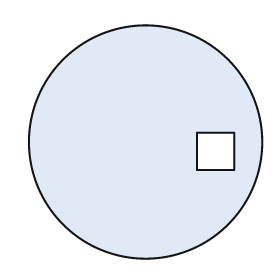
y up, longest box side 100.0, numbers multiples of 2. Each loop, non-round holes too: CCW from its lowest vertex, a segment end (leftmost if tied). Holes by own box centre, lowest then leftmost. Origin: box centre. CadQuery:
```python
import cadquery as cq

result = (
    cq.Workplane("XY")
    .moveTo(0.0, 0.0)
    .circle(50.0)
    .moveTo(22.0, -12.0)
    .lineTo(38.0, -12.0)
    .lineTo(38.0, 4.0)
    .lineTo(22.0, 4.0)
    .close()
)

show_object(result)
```